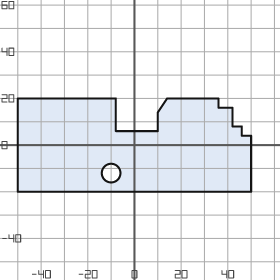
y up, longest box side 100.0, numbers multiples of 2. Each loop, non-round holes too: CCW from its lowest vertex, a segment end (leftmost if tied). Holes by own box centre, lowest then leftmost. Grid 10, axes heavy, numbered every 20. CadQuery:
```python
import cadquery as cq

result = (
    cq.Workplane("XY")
    .moveTo(-50.0, -20.0)
    .lineTo(50.0, -20.0)
    .lineTo(50.0, 4.0)
    .lineTo(46.0, 4.0)
    .lineTo(46.0, 8.0)
    .lineTo(42.0, 8.0)
    .lineTo(42.0, 16.0)
    .lineTo(36.0, 16.0)
    .lineTo(36.0, 20.0)
    .lineTo(14.0, 20.0)
    .lineTo(10.0, 14.0)
    .lineTo(10.0, 6.0)
    .lineTo(-8.0, 6.0)
    .lineTo(-8.0, 20.0)
    .lineTo(-50.0, 20.0)
    .close()
    .moveTo(-10.0, -12.0)
    .circle(4.0)
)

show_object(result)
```